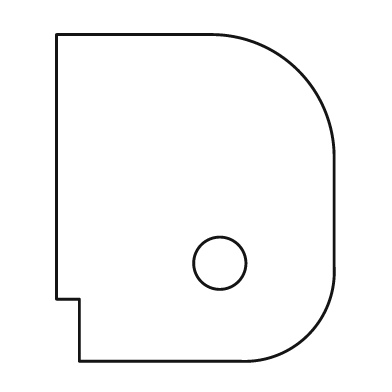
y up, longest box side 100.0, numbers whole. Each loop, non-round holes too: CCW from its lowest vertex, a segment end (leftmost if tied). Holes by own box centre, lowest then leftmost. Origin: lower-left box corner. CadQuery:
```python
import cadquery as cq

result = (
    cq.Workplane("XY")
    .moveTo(7.0, 0.0)
    .lineTo(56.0, 0.0)
    .threePointArc((77.0, 8.0), (85.0, 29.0))
    .lineTo(85.0, 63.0)
    .threePointArc((74.0, 89.0), (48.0, 100.0))
    .lineTo(0.0, 100.0)
    .lineTo(0.0, 19.0)
    .lineTo(7.0, 19.0)
    .close()
    .moveTo(50.0, 30.0)
    .circle(8.0)
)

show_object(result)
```